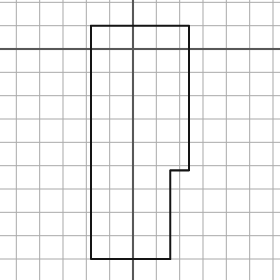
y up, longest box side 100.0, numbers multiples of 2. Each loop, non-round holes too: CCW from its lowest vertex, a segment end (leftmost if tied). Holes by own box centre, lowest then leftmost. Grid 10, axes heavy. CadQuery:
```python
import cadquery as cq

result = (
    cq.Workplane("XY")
    .moveTo(-18.0, -90.0)
    .lineTo(16.0, -90.0)
    .lineTo(16.0, -52.0)
    .lineTo(24.0, -52.0)
    .lineTo(24.0, 10.0)
    .lineTo(-18.0, 10.0)
    .close()
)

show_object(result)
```